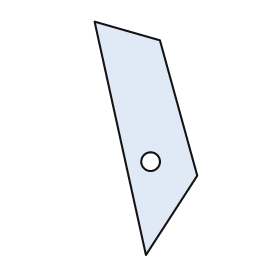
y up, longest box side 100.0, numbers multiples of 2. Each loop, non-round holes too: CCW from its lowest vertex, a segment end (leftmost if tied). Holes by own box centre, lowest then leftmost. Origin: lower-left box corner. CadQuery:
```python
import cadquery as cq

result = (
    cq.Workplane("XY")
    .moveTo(22.0, 0.0)
    .lineTo(44.0, 34.0)
    .lineTo(28.0, 92.0)
    .lineTo(0.0, 100.0)
    .close()
    .moveTo(24.0, 40.0)
    .circle(4.0)
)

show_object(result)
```